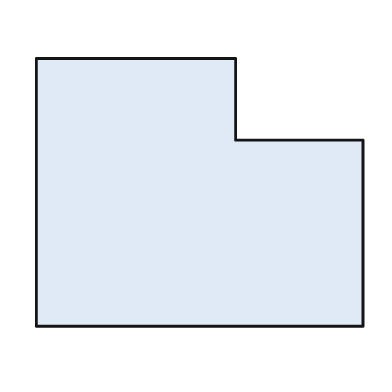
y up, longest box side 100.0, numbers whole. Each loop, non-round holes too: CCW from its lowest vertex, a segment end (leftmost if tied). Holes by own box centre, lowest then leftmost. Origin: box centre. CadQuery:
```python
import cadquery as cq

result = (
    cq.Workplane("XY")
    .moveTo(-50.0, -41.0)
    .lineTo(50.0, -41.0)
    .lineTo(50.0, 16.0)
    .lineTo(11.0, 16.0)
    .lineTo(11.0, 41.0)
    .lineTo(-50.0, 41.0)
    .close()
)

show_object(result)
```